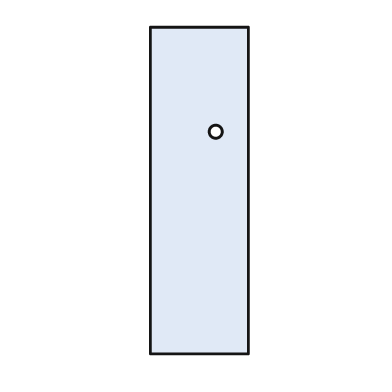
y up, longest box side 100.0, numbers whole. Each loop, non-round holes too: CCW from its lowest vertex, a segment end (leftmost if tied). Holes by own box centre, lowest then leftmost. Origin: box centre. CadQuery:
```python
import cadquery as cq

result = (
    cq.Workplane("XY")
    .moveTo(-15.0, -50.0)
    .lineTo(15.0, -50.0)
    .lineTo(15.0, 50.0)
    .lineTo(-15.0, 50.0)
    .close()
    .moveTo(5.0, 18.0)
    .circle(2.0)
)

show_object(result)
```